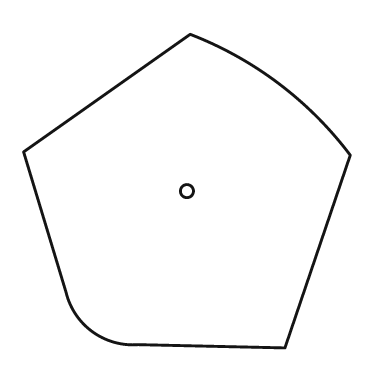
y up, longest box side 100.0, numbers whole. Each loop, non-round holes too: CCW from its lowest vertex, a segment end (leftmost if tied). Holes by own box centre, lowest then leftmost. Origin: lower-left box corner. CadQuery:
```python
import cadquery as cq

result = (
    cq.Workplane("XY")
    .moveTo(80.0, 0.0)
    .lineTo(100.0, 59.0)
    .threePointArc((78.0, 81.0), (51.0, 96.0))
    .lineTo(0.0, 60.0)
    .lineTo(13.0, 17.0)
    .threePointArc((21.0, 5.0), (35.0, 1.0))
    .close()
    .moveTo(50.0, 48.0)
    .circle(2.0)
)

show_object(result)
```